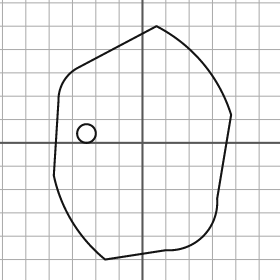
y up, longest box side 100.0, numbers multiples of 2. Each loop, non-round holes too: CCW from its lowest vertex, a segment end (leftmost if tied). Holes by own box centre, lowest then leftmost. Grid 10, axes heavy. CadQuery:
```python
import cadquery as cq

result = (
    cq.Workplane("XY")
    .moveTo(-16.0, -50.0)
    .lineTo(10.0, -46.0)
    .threePointArc((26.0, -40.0), (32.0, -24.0))
    .lineTo(38.0, 12.0)
    .threePointArc((26.0, 34.0), (6.0, 50.0))
    .lineTo(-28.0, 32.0)
    .threePointArc((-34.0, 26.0), (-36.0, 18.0))
    .lineTo(-38.0, -14.0)
    .threePointArc((-30.0, -34.0), (-16.0, -50.0))
    .close()
    .moveTo(-24.0, 4.0)
    .circle(4.0)
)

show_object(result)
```